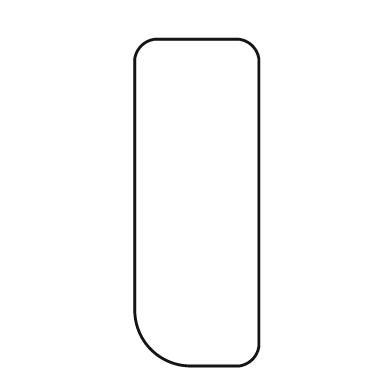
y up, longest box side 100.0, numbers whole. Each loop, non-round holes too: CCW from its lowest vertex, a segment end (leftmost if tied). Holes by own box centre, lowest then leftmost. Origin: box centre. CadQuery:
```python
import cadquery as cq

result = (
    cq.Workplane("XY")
    .moveTo(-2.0, -50.0)
    .lineTo(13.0, -50.0)
    .threePointArc((17.0, -48.0), (19.0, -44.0))
    .lineTo(19.0, 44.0)
    .threePointArc((17.0, 48.0), (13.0, 50.0))
    .lineTo(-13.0, 50.0)
    .threePointArc((-17.0, 48.0), (-19.0, 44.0))
    .lineTo(-19.0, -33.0)
    .threePointArc((-14.0, -45.0), (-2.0, -50.0))
    .close()
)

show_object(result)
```